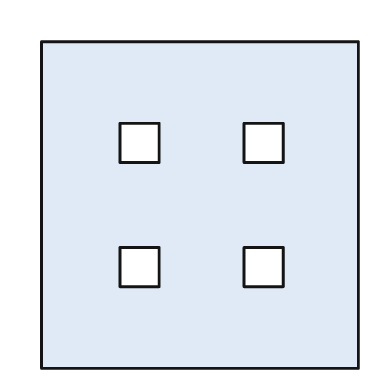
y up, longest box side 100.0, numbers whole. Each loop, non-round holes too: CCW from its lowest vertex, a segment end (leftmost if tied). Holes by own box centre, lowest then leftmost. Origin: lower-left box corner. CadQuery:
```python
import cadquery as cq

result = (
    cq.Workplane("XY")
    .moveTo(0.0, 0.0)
    .lineTo(97.0, 0.0)
    .lineTo(97.0, 100.0)
    .lineTo(0.0, 100.0)
    .close()
    .moveTo(24.0, 25.0)
    .lineTo(36.0, 25.0)
    .lineTo(36.0, 37.0)
    .lineTo(24.0, 37.0)
    .close()
    .moveTo(62.0, 25.0)
    .lineTo(74.0, 25.0)
    .lineTo(74.0, 37.0)
    .lineTo(62.0, 37.0)
    .close()
    .moveTo(24.0, 63.0)
    .lineTo(36.0, 63.0)
    .lineTo(36.0, 75.0)
    .lineTo(24.0, 75.0)
    .close()
    .moveTo(62.0, 63.0)
    .lineTo(74.0, 63.0)
    .lineTo(74.0, 75.0)
    .lineTo(62.0, 75.0)
    .close()
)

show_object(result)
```